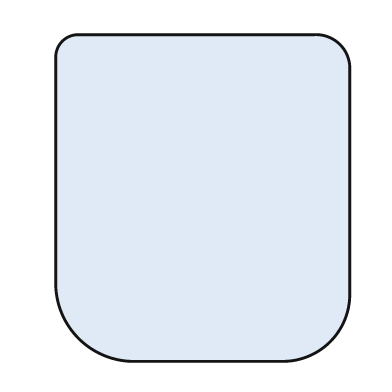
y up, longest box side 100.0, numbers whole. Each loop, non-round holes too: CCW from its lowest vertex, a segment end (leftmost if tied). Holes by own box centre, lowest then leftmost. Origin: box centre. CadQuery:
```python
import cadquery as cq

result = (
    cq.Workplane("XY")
    .moveTo(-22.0, -50.0)
    .lineTo(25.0, -50.0)
    .threePointArc((39.0, -44.0), (45.0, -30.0))
    .lineTo(45.0, 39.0)
    .threePointArc((42.0, 47.0), (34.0, 50.0))
    .lineTo(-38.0, 50.0)
    .threePointArc((-43.0, 48.0), (-45.0, 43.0))
    .lineTo(-45.0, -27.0)
    .threePointArc((-38.0, -43.0), (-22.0, -50.0))
    .close()
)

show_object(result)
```